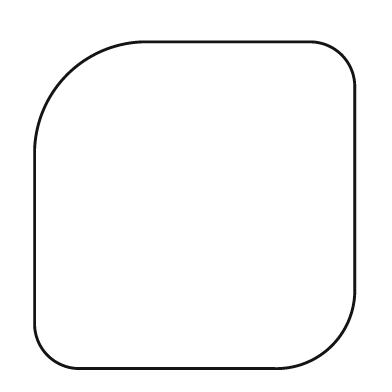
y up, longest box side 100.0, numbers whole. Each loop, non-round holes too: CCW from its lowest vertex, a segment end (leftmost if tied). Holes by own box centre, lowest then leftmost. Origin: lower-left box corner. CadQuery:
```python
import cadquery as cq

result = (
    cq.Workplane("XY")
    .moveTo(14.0, 0.0)
    .lineTo(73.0, 0.0)
    .threePointArc((91.0, 7.0), (98.0, 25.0))
    .lineTo(98.0, 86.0)
    .threePointArc((94.0, 96.0), (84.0, 100.0))
    .lineTo(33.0, 100.0)
    .threePointArc((10.0, 90.0), (0.0, 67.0))
    .lineTo(0.0, 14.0)
    .threePointArc((4.0, 4.0), (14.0, 0.0))
    .close()
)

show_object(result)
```